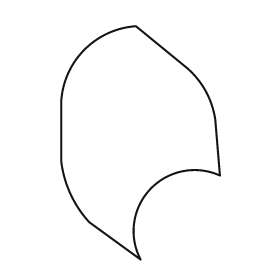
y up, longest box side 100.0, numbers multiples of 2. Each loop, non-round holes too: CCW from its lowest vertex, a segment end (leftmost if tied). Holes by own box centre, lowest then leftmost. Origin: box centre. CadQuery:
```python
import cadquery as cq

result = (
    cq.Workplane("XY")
    .moveTo(0.0, -50.0)
    .threePointArc((4.0, -20.0), (34.0, -14.0))
    .lineTo(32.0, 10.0)
    .threePointArc((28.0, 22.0), (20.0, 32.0))
    .lineTo(-2.0, 50.0)
    .threePointArc((-24.0, 40.0), (-34.0, 18.0))
    .lineTo(-34.0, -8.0)
    .threePointArc((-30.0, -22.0), (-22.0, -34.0))
    .close()
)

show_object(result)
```